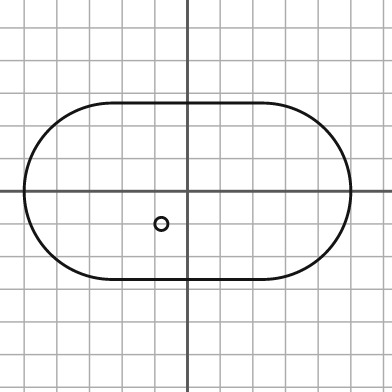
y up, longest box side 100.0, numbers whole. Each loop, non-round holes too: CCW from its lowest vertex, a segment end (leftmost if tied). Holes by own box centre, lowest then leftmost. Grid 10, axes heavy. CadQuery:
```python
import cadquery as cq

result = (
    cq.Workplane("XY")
    .moveTo(-23.0, -27.0)
    .lineTo(23.0, -27.0)
    .threePointArc((50.0, 0.0), (23.0, 27.0))
    .lineTo(-23.0, 27.0)
    .threePointArc((-50.0, 0.0), (-23.0, -27.0))
    .close()
    .moveTo(-8.0, -10.0)
    .circle(2.0)
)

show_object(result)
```